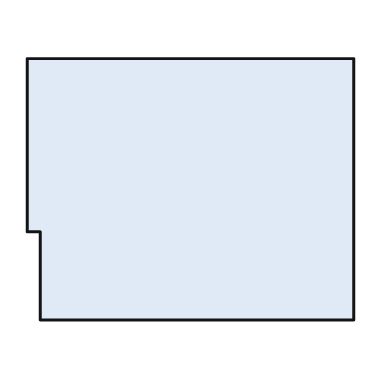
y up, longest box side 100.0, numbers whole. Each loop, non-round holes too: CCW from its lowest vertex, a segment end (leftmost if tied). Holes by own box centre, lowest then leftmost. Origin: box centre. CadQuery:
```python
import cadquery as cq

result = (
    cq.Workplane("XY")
    .moveTo(-46.0, -40.0)
    .lineTo(50.0, -40.0)
    .lineTo(50.0, 40.0)
    .lineTo(-50.0, 40.0)
    .lineTo(-50.0, -13.0)
    .lineTo(-46.0, -13.0)
    .close()
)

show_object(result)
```